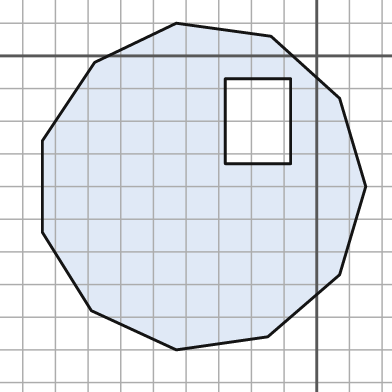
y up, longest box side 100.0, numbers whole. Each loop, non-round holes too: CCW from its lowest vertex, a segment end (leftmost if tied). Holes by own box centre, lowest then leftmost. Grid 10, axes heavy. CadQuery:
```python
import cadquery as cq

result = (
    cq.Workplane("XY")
    .moveTo(-43.0, -90.0)
    .lineTo(-15.0, -86.0)
    .lineTo(7.0, -67.0)
    .lineTo(15.0, -40.0)
    .lineTo(7.0, -13.0)
    .lineTo(-14.0, 6.0)
    .lineTo(-43.0, 10.0)
    .lineTo(-68.0, -2.0)
    .lineTo(-84.0, -26.0)
    .lineTo(-84.0, -54.0)
    .lineTo(-69.0, -78.0)
    .close()
    .moveTo(-28.0, -33.0)
    .lineTo(-8.0, -33.0)
    .lineTo(-8.0, -7.0)
    .lineTo(-28.0, -7.0)
    .close()
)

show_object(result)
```